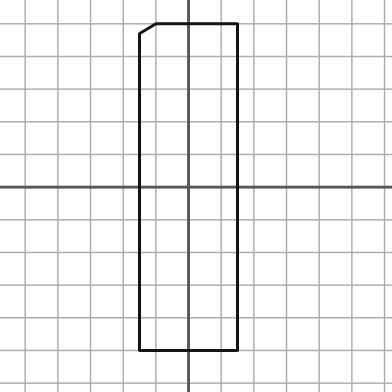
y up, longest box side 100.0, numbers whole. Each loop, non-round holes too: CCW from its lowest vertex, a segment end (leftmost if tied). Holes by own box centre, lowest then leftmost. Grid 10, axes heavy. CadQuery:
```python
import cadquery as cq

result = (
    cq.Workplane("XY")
    .moveTo(-15.0, -50.0)
    .lineTo(15.0, -50.0)
    .lineTo(15.0, 50.0)
    .lineTo(-10.0, 50.0)
    .lineTo(-15.0, 47.0)
    .close()
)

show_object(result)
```